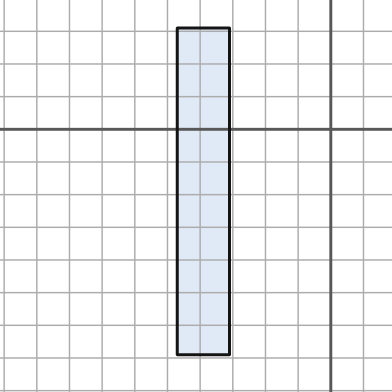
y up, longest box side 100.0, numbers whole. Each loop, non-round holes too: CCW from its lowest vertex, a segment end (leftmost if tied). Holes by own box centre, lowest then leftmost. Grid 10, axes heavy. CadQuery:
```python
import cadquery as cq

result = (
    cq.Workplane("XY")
    .moveTo(-47.0, -69.0)
    .lineTo(-31.0, -69.0)
    .lineTo(-31.0, 31.0)
    .lineTo(-47.0, 31.0)
    .close()
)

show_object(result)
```